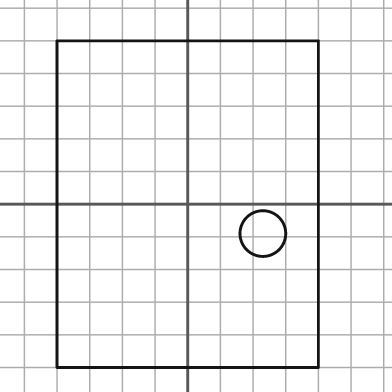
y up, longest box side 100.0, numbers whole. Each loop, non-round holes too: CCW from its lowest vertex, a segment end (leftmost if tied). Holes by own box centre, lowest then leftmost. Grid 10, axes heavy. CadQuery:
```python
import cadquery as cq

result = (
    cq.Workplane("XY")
    .moveTo(-40.0, -50.0)
    .lineTo(40.0, -50.0)
    .lineTo(40.0, 50.0)
    .lineTo(-40.0, 50.0)
    .close()
    .moveTo(23.0, -9.0)
    .circle(7.0)
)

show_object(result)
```